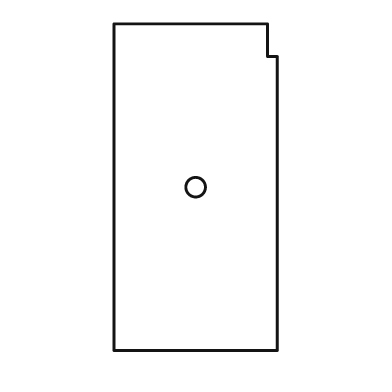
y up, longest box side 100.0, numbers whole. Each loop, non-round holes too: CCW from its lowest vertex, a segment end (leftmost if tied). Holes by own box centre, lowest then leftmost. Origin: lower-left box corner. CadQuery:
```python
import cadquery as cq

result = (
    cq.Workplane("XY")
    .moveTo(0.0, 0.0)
    .lineTo(50.0, 0.0)
    .lineTo(50.0, 90.0)
    .lineTo(47.0, 90.0)
    .lineTo(47.0, 100.0)
    .lineTo(0.0, 100.0)
    .close()
    .moveTo(25.0, 50.0)
    .circle(3.0)
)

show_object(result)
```